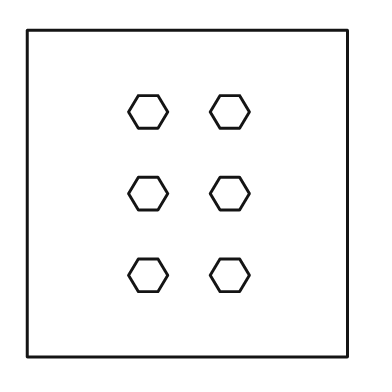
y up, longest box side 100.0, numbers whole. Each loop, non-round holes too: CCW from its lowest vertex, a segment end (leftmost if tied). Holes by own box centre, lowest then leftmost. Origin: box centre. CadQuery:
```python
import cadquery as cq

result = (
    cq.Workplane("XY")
    .moveTo(-49.0, -50.0)
    .lineTo(49.0, -50.0)
    .lineTo(49.0, 50.0)
    .lineTo(-49.0, 50.0)
    .close()
    .moveTo(-15.0, -30.0)
    .lineTo(-9.0, -30.0)
    .lineTo(-6.0, -25.0)
    .lineTo(-9.0, -20.0)
    .lineTo(-15.0, -20.0)
    .lineTo(-18.0, -25.0)
    .close()
    .moveTo(10.0, -30.0)
    .lineTo(16.0, -30.0)
    .lineTo(19.0, -25.0)
    .lineTo(16.0, -20.0)
    .lineTo(10.0, -20.0)
    .lineTo(7.0, -25.0)
    .close()
    .moveTo(-15.0, -5.0)
    .lineTo(-9.0, -5.0)
    .lineTo(-6.0, 0.0)
    .lineTo(-9.0, 5.0)
    .lineTo(-15.0, 5.0)
    .lineTo(-18.0, 0.0)
    .close()
    .moveTo(10.0, -5.0)
    .lineTo(16.0, -5.0)
    .lineTo(19.0, 0.0)
    .lineTo(16.0, 5.0)
    .lineTo(10.0, 5.0)
    .lineTo(7.0, 0.0)
    .close()
    .moveTo(-15.0, 20.0)
    .lineTo(-9.0, 20.0)
    .lineTo(-6.0, 25.0)
    .lineTo(-9.0, 30.0)
    .lineTo(-15.0, 30.0)
    .lineTo(-18.0, 25.0)
    .close()
    .moveTo(10.0, 20.0)
    .lineTo(16.0, 20.0)
    .lineTo(19.0, 25.0)
    .lineTo(16.0, 30.0)
    .lineTo(10.0, 30.0)
    .lineTo(7.0, 25.0)
    .close()
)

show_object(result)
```